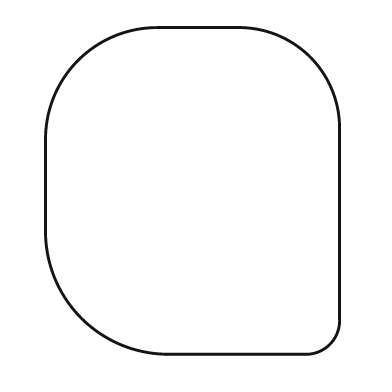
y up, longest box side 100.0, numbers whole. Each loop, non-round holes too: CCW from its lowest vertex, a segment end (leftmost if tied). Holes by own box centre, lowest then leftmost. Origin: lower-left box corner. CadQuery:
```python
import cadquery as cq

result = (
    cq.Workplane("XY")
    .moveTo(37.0, 0.0)
    .lineTo(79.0, 0.0)
    .threePointArc((87.0, 3.0), (90.0, 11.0))
    .lineTo(90.0, 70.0)
    .threePointArc((81.0, 91.0), (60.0, 100.0))
    .lineTo(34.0, 100.0)
    .threePointArc((10.0, 90.0), (0.0, 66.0))
    .lineTo(0.0, 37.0)
    .threePointArc((11.0, 11.0), (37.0, 0.0))
    .close()
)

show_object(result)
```